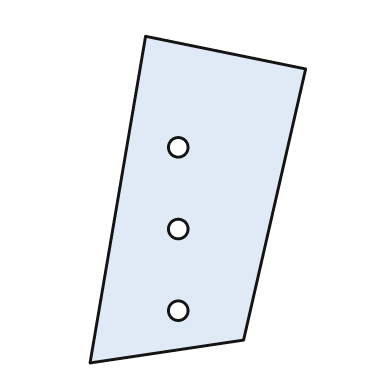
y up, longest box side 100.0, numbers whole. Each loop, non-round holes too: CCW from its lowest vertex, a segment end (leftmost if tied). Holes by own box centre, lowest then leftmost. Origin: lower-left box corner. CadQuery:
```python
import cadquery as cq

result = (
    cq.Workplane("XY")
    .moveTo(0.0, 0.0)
    .lineTo(47.0, 7.0)
    .lineTo(66.0, 90.0)
    .lineTo(17.0, 100.0)
    .close()
    .moveTo(27.0, 16.0)
    .circle(3.0)
    .moveTo(27.0, 41.0)
    .circle(3.0)
    .moveTo(27.0, 66.0)
    .circle(3.0)
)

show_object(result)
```